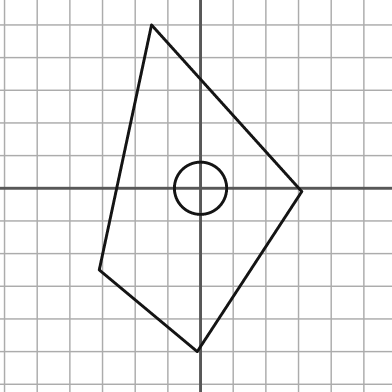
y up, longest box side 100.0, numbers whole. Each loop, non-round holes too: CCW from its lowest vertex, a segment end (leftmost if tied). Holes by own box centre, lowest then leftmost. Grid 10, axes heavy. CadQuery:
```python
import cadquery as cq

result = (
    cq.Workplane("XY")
    .moveTo(-1.0, -50.0)
    .lineTo(31.0, -1.0)
    .lineTo(-15.0, 50.0)
    .lineTo(-31.0, -25.0)
    .close()
    .moveTo(0.0, 0.0)
    .circle(8.0)
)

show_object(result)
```